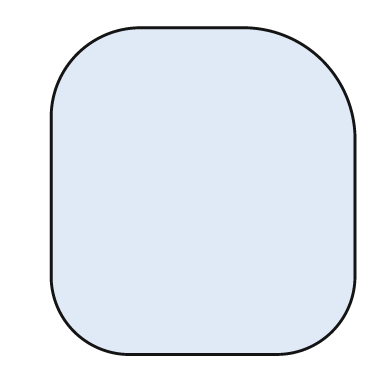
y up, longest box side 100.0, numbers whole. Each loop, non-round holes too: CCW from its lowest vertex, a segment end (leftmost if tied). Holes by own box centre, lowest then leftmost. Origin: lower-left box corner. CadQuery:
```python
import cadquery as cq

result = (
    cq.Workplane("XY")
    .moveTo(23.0, 0.0)
    .lineTo(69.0, 0.0)
    .threePointArc((86.0, 7.0), (93.0, 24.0))
    .lineTo(93.0, 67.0)
    .threePointArc((83.0, 90.0), (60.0, 100.0))
    .lineTo(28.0, 100.0)
    .threePointArc((8.0, 92.0), (0.0, 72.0))
    .lineTo(0.0, 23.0)
    .threePointArc((7.0, 7.0), (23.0, 0.0))
    .close()
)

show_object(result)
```